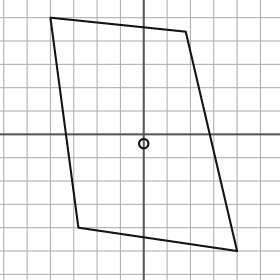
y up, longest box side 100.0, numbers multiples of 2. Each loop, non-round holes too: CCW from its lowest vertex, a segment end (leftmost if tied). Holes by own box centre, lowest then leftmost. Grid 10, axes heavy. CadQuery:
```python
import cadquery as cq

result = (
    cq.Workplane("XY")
    .moveTo(40.0, -50.0)
    .lineTo(18.0, 44.0)
    .lineTo(-40.0, 50.0)
    .lineTo(-28.0, -40.0)
    .close()
    .moveTo(0.0, -4.0)
    .circle(2.0)
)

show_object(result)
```